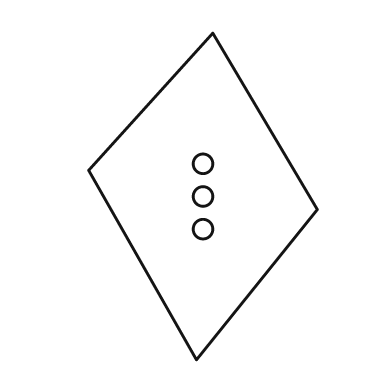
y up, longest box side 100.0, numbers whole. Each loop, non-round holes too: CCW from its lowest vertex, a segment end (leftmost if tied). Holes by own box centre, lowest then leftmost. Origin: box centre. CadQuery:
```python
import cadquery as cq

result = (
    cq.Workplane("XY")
    .moveTo(-2.0, -50.0)
    .lineTo(35.0, -4.0)
    .lineTo(3.0, 50.0)
    .lineTo(-35.0, 8.0)
    .close()
    .moveTo(0.0, -10.0)
    .circle(3.0)
    .moveTo(0.0, 0.0)
    .circle(3.0)
    .moveTo(0.0, 10.0)
    .circle(3.0)
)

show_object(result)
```